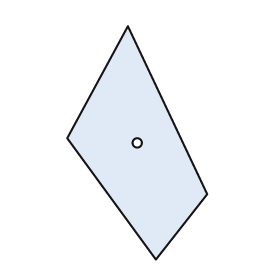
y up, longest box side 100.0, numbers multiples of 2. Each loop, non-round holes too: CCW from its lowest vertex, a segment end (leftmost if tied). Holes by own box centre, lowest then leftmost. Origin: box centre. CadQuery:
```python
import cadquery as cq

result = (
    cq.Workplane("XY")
    .moveTo(8.0, -50.0)
    .lineTo(30.0, -22.0)
    .lineTo(-4.0, 50.0)
    .lineTo(-30.0, 2.0)
    .close()
    .moveTo(0.0, 0.0)
    .circle(2.0)
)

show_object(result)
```